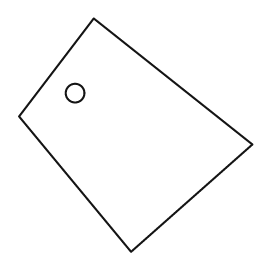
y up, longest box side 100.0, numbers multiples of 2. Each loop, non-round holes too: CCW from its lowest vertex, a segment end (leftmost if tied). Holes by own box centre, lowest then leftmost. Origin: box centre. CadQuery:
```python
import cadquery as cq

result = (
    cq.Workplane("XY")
    .moveTo(-2.0, -50.0)
    .lineTo(50.0, -4.0)
    .lineTo(-18.0, 50.0)
    .lineTo(-50.0, 8.0)
    .close()
    .moveTo(-26.0, 18.0)
    .circle(4.0)
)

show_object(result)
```